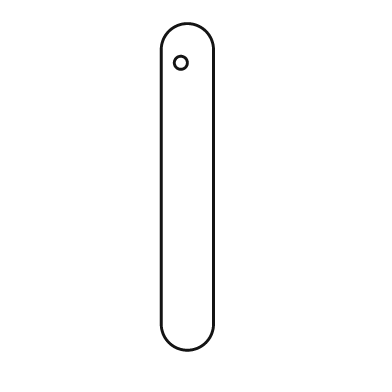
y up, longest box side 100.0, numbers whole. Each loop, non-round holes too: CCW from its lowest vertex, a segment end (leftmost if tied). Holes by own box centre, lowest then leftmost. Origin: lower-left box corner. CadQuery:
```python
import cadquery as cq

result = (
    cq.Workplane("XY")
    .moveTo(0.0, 8.0)
    .threePointArc((8.0, 0.0), (16.0, 8.0))
    .lineTo(16.0, 92.0)
    .threePointArc((8.0, 100.0), (0.0, 92.0))
    .close()
    .moveTo(6.0, 88.0)
    .circle(2.0)
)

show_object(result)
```